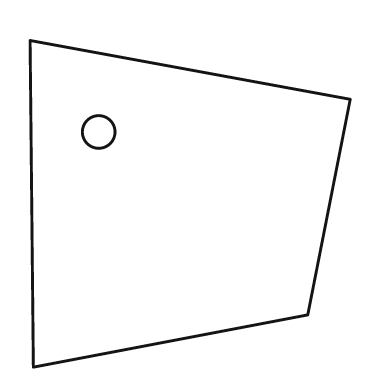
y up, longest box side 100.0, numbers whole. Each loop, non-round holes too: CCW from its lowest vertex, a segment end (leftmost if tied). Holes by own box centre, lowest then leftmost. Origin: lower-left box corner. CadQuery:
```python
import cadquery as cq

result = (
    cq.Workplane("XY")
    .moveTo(1.0, 0.0)
    .lineTo(85.0, 16.0)
    .lineTo(98.0, 82.0)
    .lineTo(0.0, 100.0)
    .close()
    .moveTo(21.0, 72.0)
    .circle(5.0)
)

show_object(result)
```